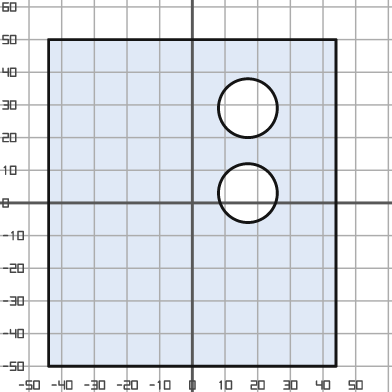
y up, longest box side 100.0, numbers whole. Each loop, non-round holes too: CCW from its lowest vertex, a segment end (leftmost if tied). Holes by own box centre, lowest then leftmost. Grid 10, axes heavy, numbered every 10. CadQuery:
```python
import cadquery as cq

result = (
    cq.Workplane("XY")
    .moveTo(-44.0, -50.0)
    .lineTo(44.0, -50.0)
    .lineTo(44.0, 50.0)
    .lineTo(-44.0, 50.0)
    .close()
    .moveTo(17.0, 3.0)
    .circle(9.0)
    .moveTo(17.0, 29.0)
    .circle(9.0)
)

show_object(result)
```